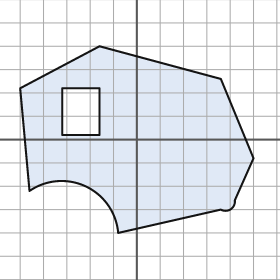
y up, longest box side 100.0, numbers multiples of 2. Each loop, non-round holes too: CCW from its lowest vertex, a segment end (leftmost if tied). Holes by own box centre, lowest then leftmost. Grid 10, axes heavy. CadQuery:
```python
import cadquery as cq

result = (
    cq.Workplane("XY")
    .moveTo(-8.0, -40.0)
    .lineTo(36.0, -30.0)
    .threePointArc((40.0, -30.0), (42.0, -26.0))
    .lineTo(50.0, -8.0)
    .lineTo(36.0, 26.0)
    .lineTo(-16.0, 40.0)
    .lineTo(-50.0, 22.0)
    .lineTo(-46.0, -22.0)
    .threePointArc((-22.0, -20.0), (-8.0, -40.0))
    .close()
    .moveTo(-32.0, 2.0)
    .lineTo(-16.0, 2.0)
    .lineTo(-16.0, 22.0)
    .lineTo(-32.0, 22.0)
    .close()
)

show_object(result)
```